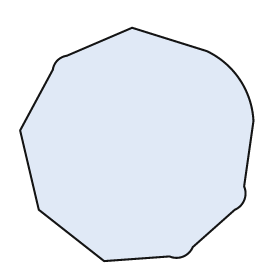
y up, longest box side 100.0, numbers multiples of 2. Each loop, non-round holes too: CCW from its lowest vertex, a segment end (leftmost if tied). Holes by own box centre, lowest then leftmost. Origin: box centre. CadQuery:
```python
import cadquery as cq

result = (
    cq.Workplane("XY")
    .moveTo(-14.0, -50.0)
    .lineTo(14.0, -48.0)
    .threePointArc((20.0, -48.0), (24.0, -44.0))
    .lineTo(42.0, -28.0)
    .threePointArc((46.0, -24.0), (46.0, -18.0))
    .lineTo(50.0, 10.0)
    .threePointArc((44.0, 28.0), (30.0, 40.0))
    .lineTo(-2.0, 50.0)
    .lineTo(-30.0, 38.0)
    .threePointArc((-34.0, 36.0), (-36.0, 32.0))
    .lineTo(-50.0, 6.0)
    .lineTo(-42.0, -28.0)
    .close()
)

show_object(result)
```